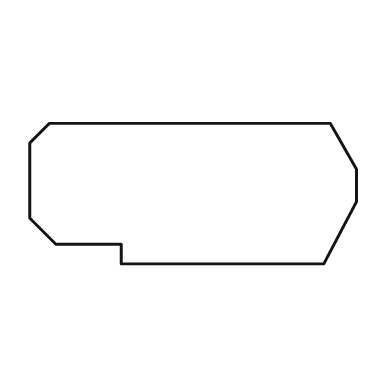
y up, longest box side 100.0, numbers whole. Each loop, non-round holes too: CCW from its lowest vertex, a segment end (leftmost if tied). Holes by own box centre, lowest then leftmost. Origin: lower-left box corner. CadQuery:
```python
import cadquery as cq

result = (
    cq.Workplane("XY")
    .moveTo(28.0, 0.0)
    .lineTo(90.0, 0.0)
    .lineTo(100.0, 19.0)
    .lineTo(100.0, 29.0)
    .lineTo(92.0, 43.0)
    .lineTo(6.0, 43.0)
    .lineTo(0.0, 37.0)
    .lineTo(0.0, 14.0)
    .lineTo(8.0, 6.0)
    .lineTo(28.0, 6.0)
    .close()
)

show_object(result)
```